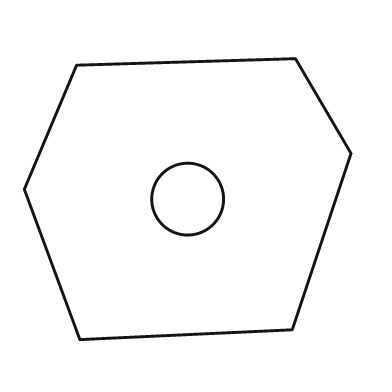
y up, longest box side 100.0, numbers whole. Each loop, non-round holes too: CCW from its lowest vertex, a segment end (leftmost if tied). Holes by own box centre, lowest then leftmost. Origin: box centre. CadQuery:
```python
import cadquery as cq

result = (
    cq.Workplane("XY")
    .moveTo(-33.0, -43.0)
    .lineTo(32.0, -40.0)
    .lineTo(50.0, 14.0)
    .lineTo(33.0, 43.0)
    .lineTo(-34.0, 41.0)
    .lineTo(-50.0, 3.0)
    .close()
    .moveTo(0.0, 0.0)
    .circle(11.0)
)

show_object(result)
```